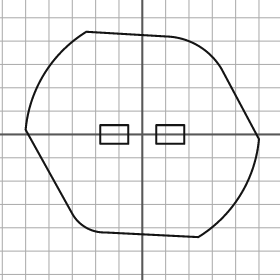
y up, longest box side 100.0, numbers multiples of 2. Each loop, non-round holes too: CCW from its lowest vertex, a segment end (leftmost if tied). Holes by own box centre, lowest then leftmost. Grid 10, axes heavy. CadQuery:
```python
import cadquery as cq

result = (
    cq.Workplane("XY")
    .moveTo(24.0, -44.0)
    .threePointArc((42.0, -26.0), (50.0, -2.0))
    .lineTo(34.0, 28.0)
    .threePointArc((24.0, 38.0), (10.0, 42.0))
    .lineTo(-24.0, 44.0)
    .threePointArc((-42.0, 26.0), (-50.0, 2.0))
    .lineTo(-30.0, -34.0)
    .threePointArc((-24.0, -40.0), (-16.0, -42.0))
    .close()
    .moveTo(-18.0, -4.0)
    .lineTo(-6.0, -4.0)
    .lineTo(-6.0, 4.0)
    .lineTo(-18.0, 4.0)
    .close()
    .moveTo(6.0, -4.0)
    .lineTo(18.0, -4.0)
    .lineTo(18.0, 4.0)
    .lineTo(6.0, 4.0)
    .close()
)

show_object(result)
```